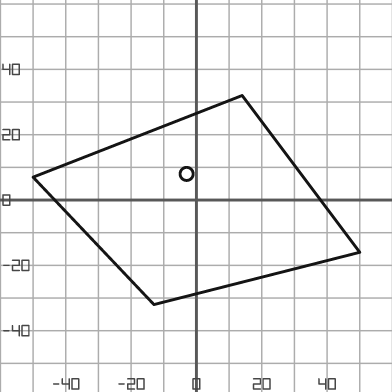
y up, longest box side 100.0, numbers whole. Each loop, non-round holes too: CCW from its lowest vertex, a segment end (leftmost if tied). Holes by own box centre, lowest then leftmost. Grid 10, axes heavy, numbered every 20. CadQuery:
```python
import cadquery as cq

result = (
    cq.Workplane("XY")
    .moveTo(-13.0, -32.0)
    .lineTo(50.0, -16.0)
    .lineTo(14.0, 32.0)
    .lineTo(-50.0, 7.0)
    .close()
    .moveTo(-3.0, 8.0)
    .circle(2.0)
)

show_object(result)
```